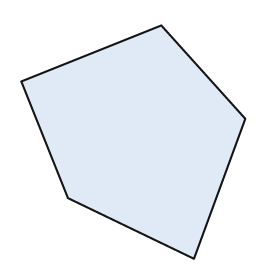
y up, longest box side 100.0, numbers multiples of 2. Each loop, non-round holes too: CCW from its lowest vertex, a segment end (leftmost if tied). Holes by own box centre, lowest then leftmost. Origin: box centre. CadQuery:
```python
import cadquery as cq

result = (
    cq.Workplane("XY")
    .moveTo(26.0, -50.0)
    .lineTo(48.0, 10.0)
    .lineTo(12.0, 50.0)
    .lineTo(-48.0, 26.0)
    .lineTo(-28.0, -24.0)
    .close()
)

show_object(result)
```